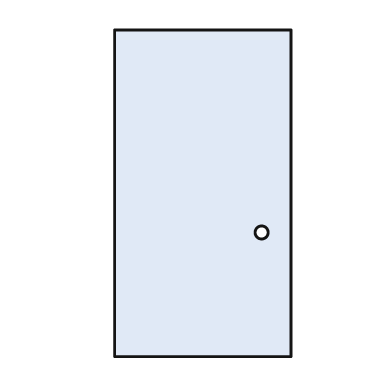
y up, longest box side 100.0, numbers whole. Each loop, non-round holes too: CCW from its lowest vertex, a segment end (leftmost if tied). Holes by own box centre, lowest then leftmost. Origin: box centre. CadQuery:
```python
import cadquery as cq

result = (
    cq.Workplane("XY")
    .moveTo(-27.0, -50.0)
    .lineTo(27.0, -50.0)
    .lineTo(27.0, 50.0)
    .lineTo(-27.0, 50.0)
    .close()
    .moveTo(18.0, -12.0)
    .circle(2.0)
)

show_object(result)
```